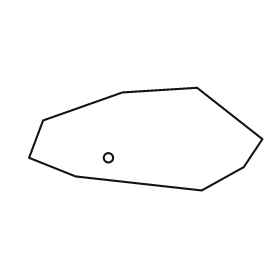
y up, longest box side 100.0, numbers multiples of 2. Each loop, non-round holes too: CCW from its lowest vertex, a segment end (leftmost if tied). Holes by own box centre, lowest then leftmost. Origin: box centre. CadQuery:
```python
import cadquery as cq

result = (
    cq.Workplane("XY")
    .moveTo(24.0, -22.0)
    .lineTo(42.0, -12.0)
    .lineTo(50.0, 0.0)
    .lineTo(22.0, 22.0)
    .lineTo(-10.0, 20.0)
    .lineTo(-44.0, 8.0)
    .lineTo(-50.0, -8.0)
    .lineTo(-30.0, -16.0)
    .close()
    .moveTo(-16.0, -8.0)
    .circle(2.0)
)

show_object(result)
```